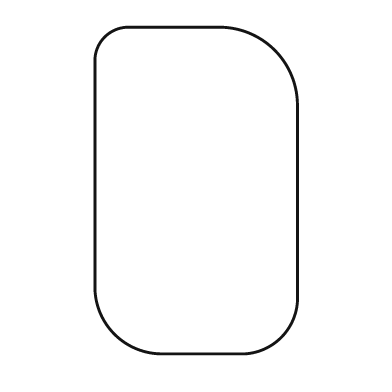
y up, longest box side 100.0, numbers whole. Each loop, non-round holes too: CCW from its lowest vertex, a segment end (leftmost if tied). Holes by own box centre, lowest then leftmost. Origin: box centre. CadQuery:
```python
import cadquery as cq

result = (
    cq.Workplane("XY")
    .moveTo(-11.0, -50.0)
    .lineTo(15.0, -50.0)
    .threePointArc((26.0, -45.0), (31.0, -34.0))
    .lineTo(31.0, 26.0)
    .threePointArc((24.0, 43.0), (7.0, 50.0))
    .lineTo(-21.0, 50.0)
    .threePointArc((-28.0, 47.0), (-31.0, 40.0))
    .lineTo(-31.0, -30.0)
    .threePointArc((-25.0, -44.0), (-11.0, -50.0))
    .close()
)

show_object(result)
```